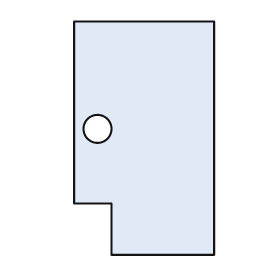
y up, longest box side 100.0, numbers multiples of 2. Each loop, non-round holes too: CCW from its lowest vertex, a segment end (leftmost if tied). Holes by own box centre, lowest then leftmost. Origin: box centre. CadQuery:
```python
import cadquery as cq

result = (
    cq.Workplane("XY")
    .moveTo(-14.0, -50.0)
    .lineTo(30.0, -50.0)
    .lineTo(30.0, 50.0)
    .lineTo(-30.0, 50.0)
    .lineTo(-30.0, -28.0)
    .lineTo(-14.0, -28.0)
    .close()
    .moveTo(-20.0, 4.0)
    .circle(6.0)
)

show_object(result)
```